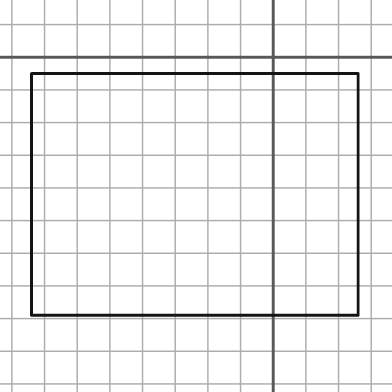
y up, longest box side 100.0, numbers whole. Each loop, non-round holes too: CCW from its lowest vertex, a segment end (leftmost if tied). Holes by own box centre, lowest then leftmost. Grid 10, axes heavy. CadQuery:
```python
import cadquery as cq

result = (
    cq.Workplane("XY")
    .moveTo(-74.0, -79.0)
    .lineTo(26.0, -79.0)
    .lineTo(26.0, -5.0)
    .lineTo(-74.0, -5.0)
    .close()
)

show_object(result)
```